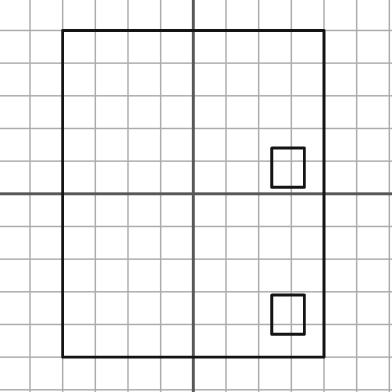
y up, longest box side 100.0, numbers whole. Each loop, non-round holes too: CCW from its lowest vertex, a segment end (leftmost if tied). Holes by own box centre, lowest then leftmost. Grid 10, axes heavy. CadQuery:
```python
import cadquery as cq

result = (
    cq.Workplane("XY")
    .moveTo(-40.0, -50.0)
    .lineTo(40.0, -50.0)
    .lineTo(40.0, 50.0)
    .lineTo(-40.0, 50.0)
    .close()
    .moveTo(24.0, -43.0)
    .lineTo(34.0, -43.0)
    .lineTo(34.0, -31.0)
    .lineTo(24.0, -31.0)
    .close()
    .moveTo(24.0, 2.0)
    .lineTo(34.0, 2.0)
    .lineTo(34.0, 14.0)
    .lineTo(24.0, 14.0)
    .close()
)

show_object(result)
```